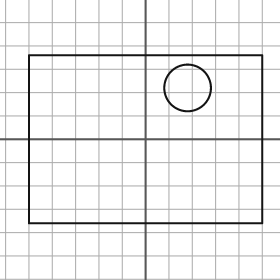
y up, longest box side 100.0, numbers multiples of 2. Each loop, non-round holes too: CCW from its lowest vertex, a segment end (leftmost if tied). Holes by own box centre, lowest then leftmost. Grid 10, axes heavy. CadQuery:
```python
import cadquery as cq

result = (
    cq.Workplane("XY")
    .moveTo(-50.0, -36.0)
    .lineTo(50.0, -36.0)
    .lineTo(50.0, 36.0)
    .lineTo(-50.0, 36.0)
    .close()
    .moveTo(18.0, 22.0)
    .circle(10.0)
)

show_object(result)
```